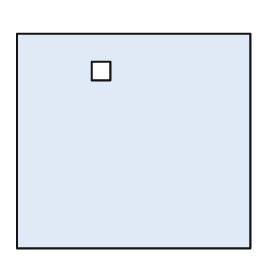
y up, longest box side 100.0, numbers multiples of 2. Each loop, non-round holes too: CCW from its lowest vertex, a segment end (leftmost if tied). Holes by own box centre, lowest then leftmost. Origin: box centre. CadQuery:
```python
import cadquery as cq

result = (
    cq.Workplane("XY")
    .moveTo(-50.0, -46.0)
    .lineTo(50.0, -46.0)
    .lineTo(50.0, 46.0)
    .lineTo(-50.0, 46.0)
    .close()
    .moveTo(-18.0, 26.0)
    .lineTo(-10.0, 26.0)
    .lineTo(-10.0, 34.0)
    .lineTo(-18.0, 34.0)
    .close()
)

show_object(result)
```